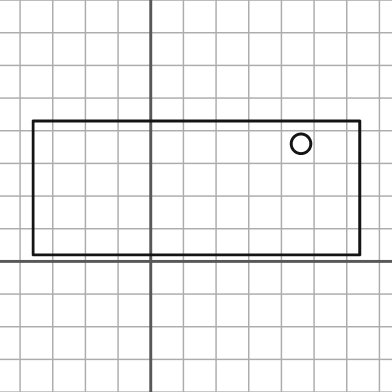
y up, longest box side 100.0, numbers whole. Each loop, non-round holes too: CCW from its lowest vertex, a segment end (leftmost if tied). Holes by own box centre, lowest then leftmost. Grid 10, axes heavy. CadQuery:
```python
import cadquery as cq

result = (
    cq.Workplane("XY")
    .moveTo(-36.0, 2.0)
    .lineTo(64.0, 2.0)
    .lineTo(64.0, 43.0)
    .lineTo(-36.0, 43.0)
    .close()
    .moveTo(46.0, 36.0)
    .circle(3.0)
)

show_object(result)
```